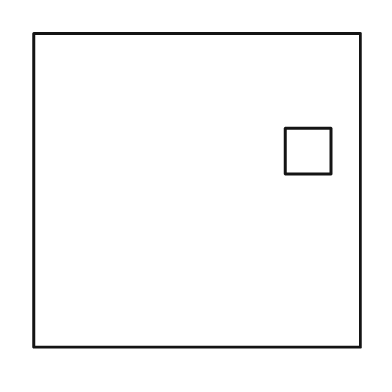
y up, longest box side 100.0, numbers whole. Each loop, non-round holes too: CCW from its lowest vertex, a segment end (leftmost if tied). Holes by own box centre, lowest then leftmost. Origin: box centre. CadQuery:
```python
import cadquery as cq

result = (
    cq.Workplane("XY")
    .moveTo(-50.0, -48.0)
    .lineTo(50.0, -48.0)
    .lineTo(50.0, 48.0)
    .lineTo(-50.0, 48.0)
    .close()
    .moveTo(27.0, 5.0)
    .lineTo(41.0, 5.0)
    .lineTo(41.0, 19.0)
    .lineTo(27.0, 19.0)
    .close()
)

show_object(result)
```